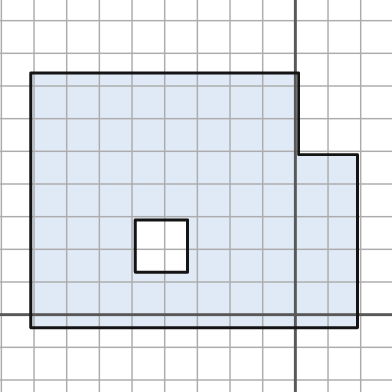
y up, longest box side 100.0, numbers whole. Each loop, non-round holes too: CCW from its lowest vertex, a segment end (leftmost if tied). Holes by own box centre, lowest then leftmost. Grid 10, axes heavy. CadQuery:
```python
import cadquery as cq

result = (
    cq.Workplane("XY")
    .moveTo(-81.0, -4.0)
    .lineTo(19.0, -4.0)
    .lineTo(19.0, 49.0)
    .lineTo(1.0, 49.0)
    .lineTo(1.0, 74.0)
    .lineTo(-81.0, 74.0)
    .close()
    .moveTo(-49.0, 13.0)
    .lineTo(-33.0, 13.0)
    .lineTo(-33.0, 29.0)
    .lineTo(-49.0, 29.0)
    .close()
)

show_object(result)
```